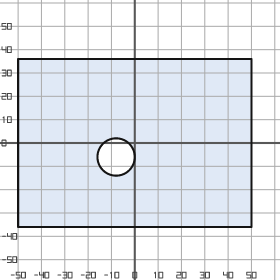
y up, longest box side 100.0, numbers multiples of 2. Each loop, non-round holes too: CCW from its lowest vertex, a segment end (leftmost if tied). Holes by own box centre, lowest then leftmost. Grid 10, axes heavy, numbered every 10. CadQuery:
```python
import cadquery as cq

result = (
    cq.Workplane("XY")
    .moveTo(-50.0, -36.0)
    .lineTo(50.0, -36.0)
    .lineTo(50.0, 36.0)
    .lineTo(-50.0, 36.0)
    .close()
    .moveTo(-8.0, -6.0)
    .circle(8.0)
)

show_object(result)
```